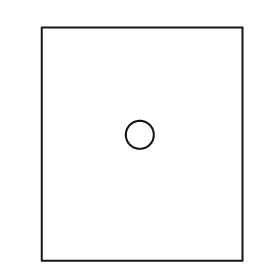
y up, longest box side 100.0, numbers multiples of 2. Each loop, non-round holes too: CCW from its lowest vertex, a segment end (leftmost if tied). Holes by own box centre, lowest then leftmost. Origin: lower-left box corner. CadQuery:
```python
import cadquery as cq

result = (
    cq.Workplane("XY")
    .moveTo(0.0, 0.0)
    .lineTo(86.0, 0.0)
    .lineTo(86.0, 100.0)
    .lineTo(0.0, 100.0)
    .close()
    .moveTo(42.0, 54.0)
    .circle(6.0)
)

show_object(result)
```